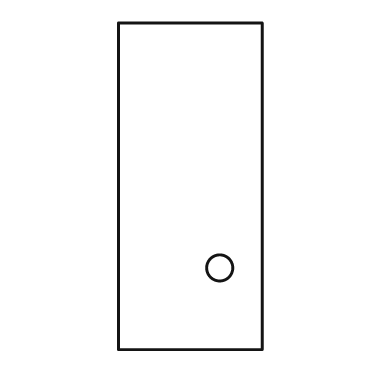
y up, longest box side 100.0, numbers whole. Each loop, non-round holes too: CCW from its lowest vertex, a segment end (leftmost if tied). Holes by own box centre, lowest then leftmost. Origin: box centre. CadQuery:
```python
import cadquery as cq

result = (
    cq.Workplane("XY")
    .moveTo(-22.0, -50.0)
    .lineTo(22.0, -50.0)
    .lineTo(22.0, 50.0)
    .lineTo(-22.0, 50.0)
    .close()
    .moveTo(9.0, -25.0)
    .circle(4.0)
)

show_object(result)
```